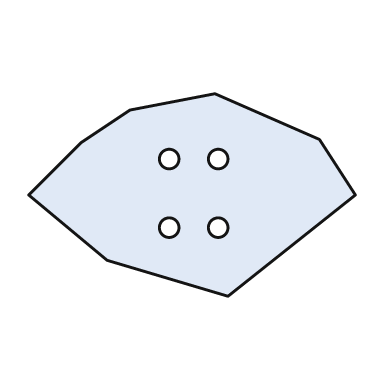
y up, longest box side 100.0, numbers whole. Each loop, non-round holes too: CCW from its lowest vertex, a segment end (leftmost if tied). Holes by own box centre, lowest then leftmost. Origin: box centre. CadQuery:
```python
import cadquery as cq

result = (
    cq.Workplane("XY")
    .moveTo(11.0, -31.0)
    .lineTo(50.0, 0.0)
    .lineTo(39.0, 17.0)
    .lineTo(7.0, 31.0)
    .lineTo(-19.0, 26.0)
    .lineTo(-34.0, 16.0)
    .lineTo(-50.0, 0.0)
    .lineTo(-26.0, -20.0)
    .close()
    .moveTo(-7.0, -10.0)
    .circle(3.0)
    .moveTo(8.0, -10.0)
    .circle(3.0)
    .moveTo(-7.0, 11.0)
    .circle(3.0)
    .moveTo(8.0, 11.0)
    .circle(3.0)
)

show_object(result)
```